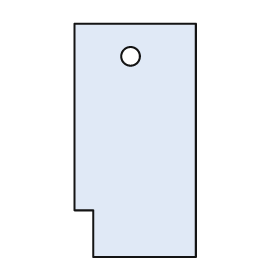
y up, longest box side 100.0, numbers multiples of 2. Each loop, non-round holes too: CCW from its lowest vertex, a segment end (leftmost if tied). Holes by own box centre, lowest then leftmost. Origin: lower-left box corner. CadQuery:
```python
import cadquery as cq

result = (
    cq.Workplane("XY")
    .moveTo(8.0, 0.0)
    .lineTo(52.0, 0.0)
    .lineTo(52.0, 100.0)
    .lineTo(0.0, 100.0)
    .lineTo(0.0, 20.0)
    .lineTo(8.0, 20.0)
    .close()
    .moveTo(24.0, 86.0)
    .circle(4.0)
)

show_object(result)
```